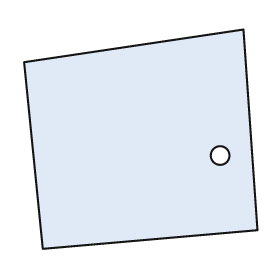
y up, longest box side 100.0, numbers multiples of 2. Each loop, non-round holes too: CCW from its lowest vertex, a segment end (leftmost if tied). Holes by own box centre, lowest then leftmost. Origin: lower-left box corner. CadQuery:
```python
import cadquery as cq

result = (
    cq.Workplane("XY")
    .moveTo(8.0, 0.0)
    .lineTo(100.0, 8.0)
    .lineTo(94.0, 94.0)
    .lineTo(0.0, 80.0)
    .close()
    .moveTo(84.0, 40.0)
    .circle(4.0)
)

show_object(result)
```